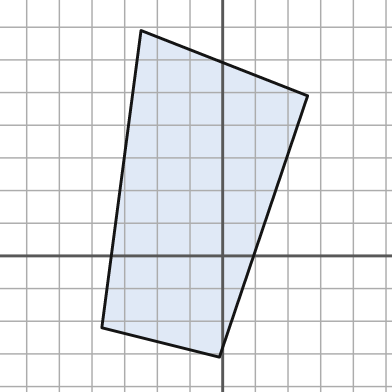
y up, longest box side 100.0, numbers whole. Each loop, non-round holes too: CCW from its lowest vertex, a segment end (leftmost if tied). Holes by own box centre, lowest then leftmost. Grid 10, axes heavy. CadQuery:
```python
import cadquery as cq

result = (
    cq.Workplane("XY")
    .moveTo(-1.0, -31.0)
    .lineTo(26.0, 49.0)
    .lineTo(-25.0, 69.0)
    .lineTo(-37.0, -22.0)
    .close()
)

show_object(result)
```